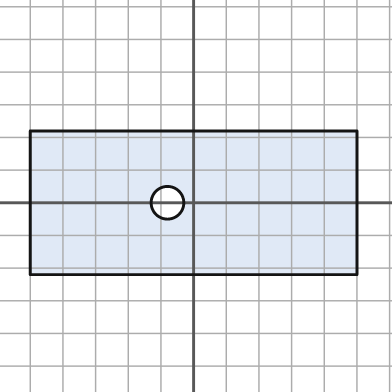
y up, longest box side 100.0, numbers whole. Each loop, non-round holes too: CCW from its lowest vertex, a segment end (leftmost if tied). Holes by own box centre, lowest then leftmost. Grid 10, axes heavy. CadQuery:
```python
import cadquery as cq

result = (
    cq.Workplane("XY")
    .moveTo(-50.0, -22.0)
    .lineTo(50.0, -22.0)
    .lineTo(50.0, 22.0)
    .lineTo(-50.0, 22.0)
    .close()
    .moveTo(-8.0, 0.0)
    .circle(5.0)
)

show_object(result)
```